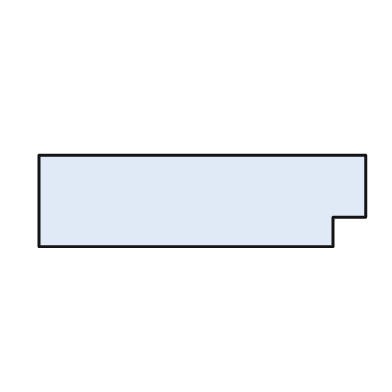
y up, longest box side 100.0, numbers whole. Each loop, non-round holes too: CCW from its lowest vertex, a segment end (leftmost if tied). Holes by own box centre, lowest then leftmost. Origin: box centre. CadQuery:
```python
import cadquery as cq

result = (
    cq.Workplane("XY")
    .moveTo(-50.0, -14.0)
    .lineTo(40.0, -14.0)
    .lineTo(40.0, -5.0)
    .lineTo(50.0, -5.0)
    .lineTo(50.0, 14.0)
    .lineTo(-50.0, 14.0)
    .close()
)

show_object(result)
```